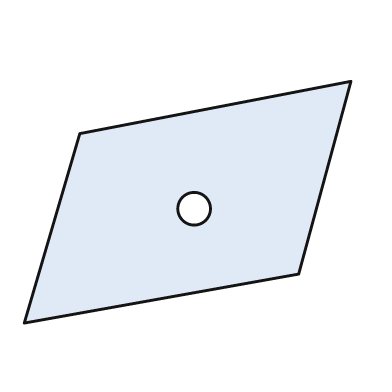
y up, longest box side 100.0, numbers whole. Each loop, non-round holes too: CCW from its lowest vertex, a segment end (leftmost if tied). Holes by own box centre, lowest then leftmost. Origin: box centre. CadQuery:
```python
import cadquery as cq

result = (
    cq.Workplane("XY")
    .moveTo(-50.0, -37.0)
    .lineTo(34.0, -22.0)
    .lineTo(50.0, 37.0)
    .lineTo(-33.0, 21.0)
    .close()
    .moveTo(2.0, -2.0)
    .circle(5.0)
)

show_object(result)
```